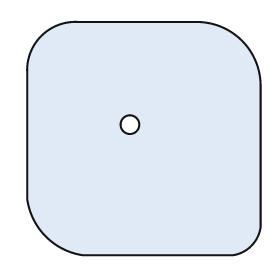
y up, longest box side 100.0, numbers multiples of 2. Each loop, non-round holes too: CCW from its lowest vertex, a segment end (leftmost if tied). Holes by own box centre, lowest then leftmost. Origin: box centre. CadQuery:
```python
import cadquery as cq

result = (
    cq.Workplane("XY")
    .moveTo(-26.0, -50.0)
    .lineTo(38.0, -50.0)
    .threePointArc((46.0, -46.0), (50.0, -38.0))
    .lineTo(50.0, 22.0)
    .threePointArc((42.0, 42.0), (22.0, 50.0))
    .lineTo(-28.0, 50.0)
    .threePointArc((-44.0, 44.0), (-50.0, 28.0))
    .lineTo(-50.0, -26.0)
    .threePointArc((-42.0, -42.0), (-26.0, -50.0))
    .close()
    .moveTo(-6.0, 6.0)
    .circle(4.0)
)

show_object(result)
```